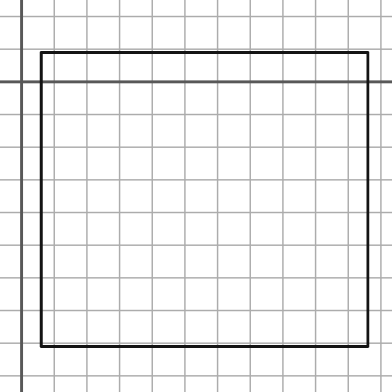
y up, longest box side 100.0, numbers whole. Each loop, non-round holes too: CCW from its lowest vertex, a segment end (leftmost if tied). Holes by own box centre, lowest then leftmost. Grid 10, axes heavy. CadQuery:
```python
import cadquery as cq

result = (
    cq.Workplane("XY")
    .moveTo(6.0, -81.0)
    .lineTo(106.0, -81.0)
    .lineTo(106.0, 9.0)
    .lineTo(6.0, 9.0)
    .close()
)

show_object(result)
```